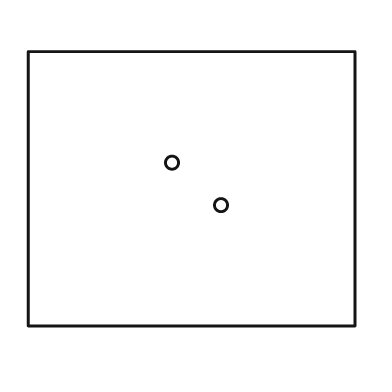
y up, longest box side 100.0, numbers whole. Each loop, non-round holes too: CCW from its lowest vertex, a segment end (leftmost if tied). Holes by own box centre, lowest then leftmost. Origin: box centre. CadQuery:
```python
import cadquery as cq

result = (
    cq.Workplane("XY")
    .moveTo(-50.0, -42.0)
    .lineTo(50.0, -42.0)
    .lineTo(50.0, 42.0)
    .lineTo(-50.0, 42.0)
    .close()
    .moveTo(9.0, -5.0)
    .circle(2.0)
    .moveTo(-6.0, 8.0)
    .circle(2.0)
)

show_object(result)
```